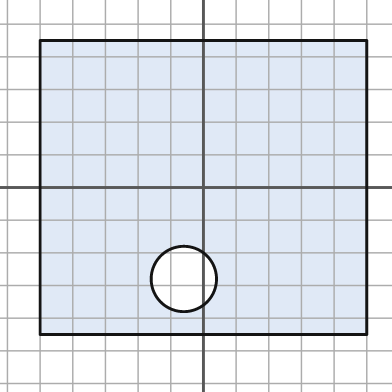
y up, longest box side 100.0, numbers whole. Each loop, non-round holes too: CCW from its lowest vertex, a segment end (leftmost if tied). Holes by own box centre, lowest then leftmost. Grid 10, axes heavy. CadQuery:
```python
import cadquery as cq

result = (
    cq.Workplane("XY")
    .moveTo(-50.0, -45.0)
    .lineTo(50.0, -45.0)
    .lineTo(50.0, 45.0)
    .lineTo(-50.0, 45.0)
    .close()
    .moveTo(-6.0, -28.0)
    .circle(10.0)
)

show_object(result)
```